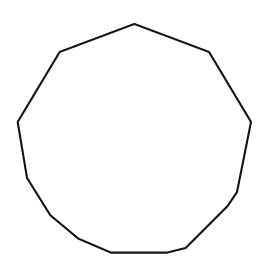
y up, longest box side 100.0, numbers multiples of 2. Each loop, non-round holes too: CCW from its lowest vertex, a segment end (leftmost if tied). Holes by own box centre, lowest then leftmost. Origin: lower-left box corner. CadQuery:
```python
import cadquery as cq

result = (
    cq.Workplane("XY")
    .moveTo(40.0, 0.0)
    .lineTo(64.0, 0.0)
    .lineTo(72.0, 2.0)
    .lineTo(90.0, 20.0)
    .lineTo(94.0, 26.0)
    .lineTo(100.0, 56.0)
    .lineTo(82.0, 86.0)
    .lineTo(50.0, 98.0)
    .lineTo(18.0, 86.0)
    .lineTo(0.0, 56.0)
    .lineTo(4.0, 32.0)
    .lineTo(14.0, 16.0)
    .lineTo(26.0, 6.0)
    .close()
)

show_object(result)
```